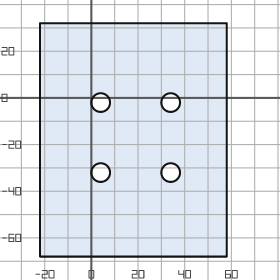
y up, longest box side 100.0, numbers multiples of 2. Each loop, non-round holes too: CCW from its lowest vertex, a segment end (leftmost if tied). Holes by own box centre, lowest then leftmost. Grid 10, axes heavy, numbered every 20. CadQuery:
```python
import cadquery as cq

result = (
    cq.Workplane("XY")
    .moveTo(-22.0, -68.0)
    .lineTo(58.0, -68.0)
    .lineTo(58.0, 32.0)
    .lineTo(-22.0, 32.0)
    .close()
    .moveTo(4.0, -32.0)
    .circle(4.0)
    .moveTo(34.0, -32.0)
    .circle(4.0)
    .moveTo(4.0, -2.0)
    .circle(4.0)
    .moveTo(34.0, -2.0)
    .circle(4.0)
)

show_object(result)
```